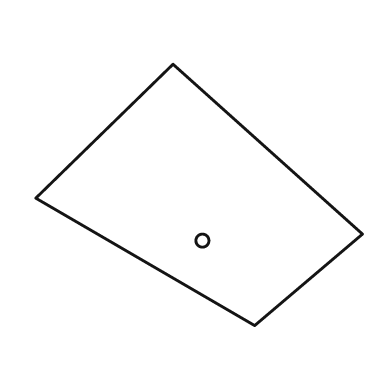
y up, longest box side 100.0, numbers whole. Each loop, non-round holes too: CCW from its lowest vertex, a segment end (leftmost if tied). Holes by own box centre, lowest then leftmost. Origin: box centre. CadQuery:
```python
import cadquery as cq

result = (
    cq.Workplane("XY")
    .moveTo(17.0, -40.0)
    .lineTo(50.0, -12.0)
    .lineTo(-8.0, 40.0)
    .lineTo(-50.0, -1.0)
    .close()
    .moveTo(1.0, -14.0)
    .circle(2.0)
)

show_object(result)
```